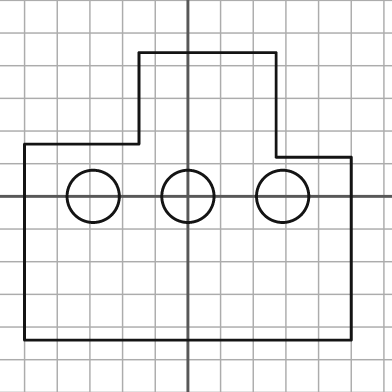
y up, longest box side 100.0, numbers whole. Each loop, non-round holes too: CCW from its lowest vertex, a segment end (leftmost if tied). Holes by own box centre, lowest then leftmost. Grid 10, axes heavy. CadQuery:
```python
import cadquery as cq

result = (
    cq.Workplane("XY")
    .moveTo(-50.0, -44.0)
    .lineTo(50.0, -44.0)
    .lineTo(50.0, 12.0)
    .lineTo(27.0, 12.0)
    .lineTo(27.0, 44.0)
    .lineTo(-15.0, 44.0)
    .lineTo(-15.0, 16.0)
    .lineTo(-50.0, 16.0)
    .close()
    .moveTo(-29.0, 0.0)
    .circle(8.0)
    .moveTo(0.0, 0.0)
    .circle(8.0)
    .moveTo(29.0, 0.0)
    .circle(8.0)
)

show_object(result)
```